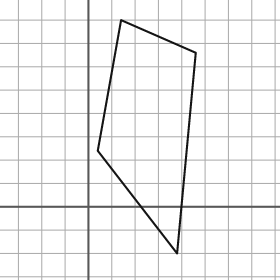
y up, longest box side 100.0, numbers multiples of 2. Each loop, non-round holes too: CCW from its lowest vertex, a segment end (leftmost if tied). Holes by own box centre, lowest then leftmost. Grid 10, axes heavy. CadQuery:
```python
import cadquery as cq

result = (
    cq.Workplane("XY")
    .moveTo(38.0, -20.0)
    .lineTo(46.0, 66.0)
    .lineTo(14.0, 80.0)
    .lineTo(4.0, 24.0)
    .close()
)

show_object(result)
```